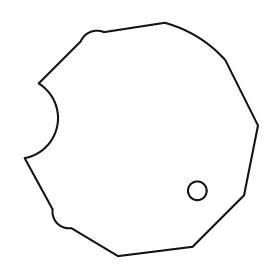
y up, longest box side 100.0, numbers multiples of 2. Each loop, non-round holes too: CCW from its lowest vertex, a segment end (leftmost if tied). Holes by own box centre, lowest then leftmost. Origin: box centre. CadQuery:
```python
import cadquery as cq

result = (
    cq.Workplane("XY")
    .moveTo(-10.0, -50.0)
    .lineTo(22.0, -46.0)
    .lineTo(44.0, -24.0)
    .lineTo(50.0, 6.0)
    .lineTo(36.0, 34.0)
    .threePointArc((24.0, 44.0), (10.0, 50.0))
    .lineTo(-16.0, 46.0)
    .threePointArc((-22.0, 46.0), (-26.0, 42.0))
    .lineTo(-44.0, 24.0)
    .threePointArc((-36.0, 6.0), (-50.0, -8.0))
    .lineTo(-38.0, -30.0)
    .threePointArc((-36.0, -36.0), (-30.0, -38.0))
    .close()
    .moveTo(24.0, -22.0)
    .circle(4.0)
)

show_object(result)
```